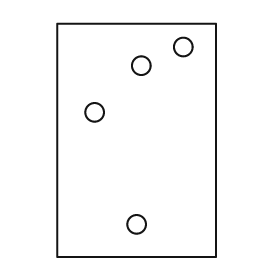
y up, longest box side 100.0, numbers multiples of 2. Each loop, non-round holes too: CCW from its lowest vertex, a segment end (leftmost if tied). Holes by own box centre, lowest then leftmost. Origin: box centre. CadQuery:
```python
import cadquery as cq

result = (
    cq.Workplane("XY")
    .moveTo(-34.0, -50.0)
    .lineTo(34.0, -50.0)
    .lineTo(34.0, 50.0)
    .lineTo(-34.0, 50.0)
    .close()
    .moveTo(0.0, -36.0)
    .circle(4.0)
    .moveTo(-18.0, 12.0)
    .circle(4.0)
    .moveTo(2.0, 32.0)
    .circle(4.0)
    .moveTo(20.0, 40.0)
    .circle(4.0)
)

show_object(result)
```